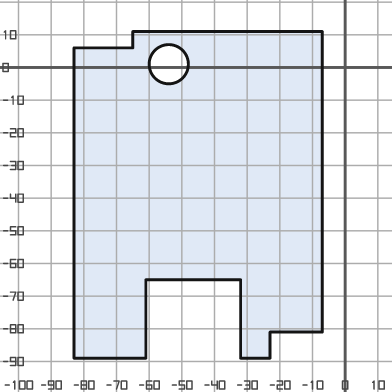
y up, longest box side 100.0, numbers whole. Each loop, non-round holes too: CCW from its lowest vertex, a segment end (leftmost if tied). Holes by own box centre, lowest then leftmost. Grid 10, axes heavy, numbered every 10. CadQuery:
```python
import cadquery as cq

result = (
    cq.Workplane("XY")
    .moveTo(-83.0, -89.0)
    .lineTo(-61.0, -89.0)
    .lineTo(-61.0, -65.0)
    .lineTo(-32.0, -65.0)
    .lineTo(-32.0, -89.0)
    .lineTo(-23.0, -89.0)
    .lineTo(-23.0, -81.0)
    .lineTo(-7.0, -81.0)
    .lineTo(-7.0, 11.0)
    .lineTo(-65.0, 11.0)
    .lineTo(-65.0, 6.0)
    .lineTo(-83.0, 6.0)
    .close()
    .moveTo(-54.0, 1.0)
    .circle(6.0)
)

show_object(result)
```